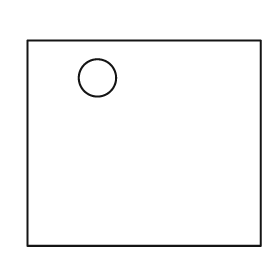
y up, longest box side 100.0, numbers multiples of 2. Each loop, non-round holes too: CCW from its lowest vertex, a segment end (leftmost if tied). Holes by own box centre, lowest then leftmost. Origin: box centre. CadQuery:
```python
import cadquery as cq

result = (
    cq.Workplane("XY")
    .moveTo(-50.0, -44.0)
    .lineTo(50.0, -44.0)
    .lineTo(50.0, 44.0)
    .lineTo(-50.0, 44.0)
    .close()
    .moveTo(-20.0, 28.0)
    .circle(8.0)
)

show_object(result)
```